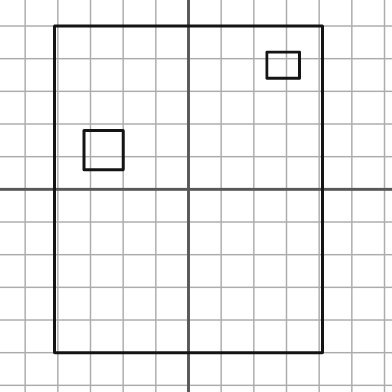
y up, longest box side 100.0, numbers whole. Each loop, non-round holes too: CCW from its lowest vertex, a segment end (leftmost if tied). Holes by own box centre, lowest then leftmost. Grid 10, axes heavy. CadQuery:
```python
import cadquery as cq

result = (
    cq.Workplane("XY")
    .moveTo(-41.0, -50.0)
    .lineTo(41.0, -50.0)
    .lineTo(41.0, 50.0)
    .lineTo(-41.0, 50.0)
    .close()
    .moveTo(-32.0, 6.0)
    .lineTo(-20.0, 6.0)
    .lineTo(-20.0, 18.0)
    .lineTo(-32.0, 18.0)
    .close()
    .moveTo(24.0, 34.0)
    .lineTo(34.0, 34.0)
    .lineTo(34.0, 42.0)
    .lineTo(24.0, 42.0)
    .close()
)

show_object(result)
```